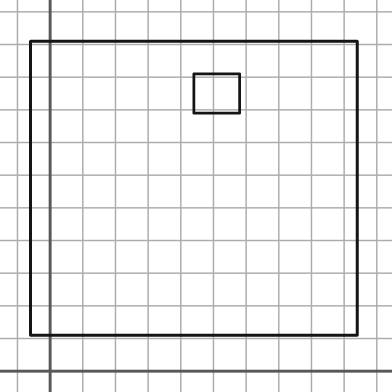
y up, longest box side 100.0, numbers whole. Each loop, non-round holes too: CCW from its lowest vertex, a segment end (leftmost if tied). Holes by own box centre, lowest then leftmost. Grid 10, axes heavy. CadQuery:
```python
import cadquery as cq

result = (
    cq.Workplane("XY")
    .moveTo(-6.0, 11.0)
    .lineTo(94.0, 11.0)
    .lineTo(94.0, 101.0)
    .lineTo(-6.0, 101.0)
    .close()
    .moveTo(44.0, 79.0)
    .lineTo(58.0, 79.0)
    .lineTo(58.0, 91.0)
    .lineTo(44.0, 91.0)
    .close()
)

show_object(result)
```